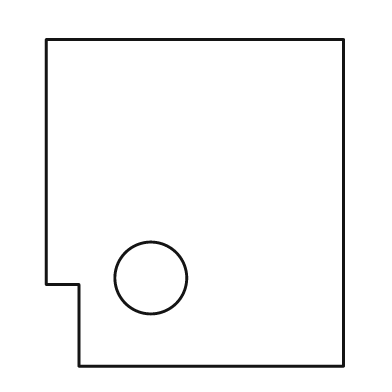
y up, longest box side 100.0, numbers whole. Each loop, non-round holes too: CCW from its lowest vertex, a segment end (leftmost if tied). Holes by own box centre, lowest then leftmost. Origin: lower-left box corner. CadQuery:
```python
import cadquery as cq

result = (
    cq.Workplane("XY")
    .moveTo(10.0, 0.0)
    .lineTo(91.0, 0.0)
    .lineTo(91.0, 100.0)
    .lineTo(0.0, 100.0)
    .lineTo(0.0, 25.0)
    .lineTo(10.0, 25.0)
    .close()
    .moveTo(32.0, 27.0)
    .circle(11.0)
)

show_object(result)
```